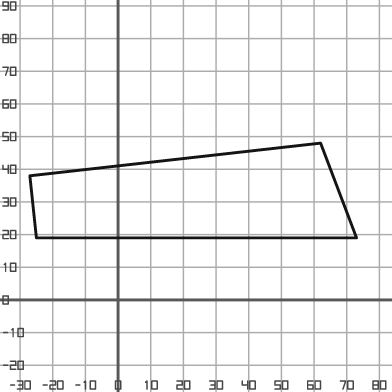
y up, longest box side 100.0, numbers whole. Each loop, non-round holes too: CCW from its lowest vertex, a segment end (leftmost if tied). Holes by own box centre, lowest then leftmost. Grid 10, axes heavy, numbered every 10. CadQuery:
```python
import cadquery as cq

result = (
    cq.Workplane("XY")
    .moveTo(-25.0, 19.0)
    .lineTo(73.0, 19.0)
    .lineTo(62.0, 48.0)
    .lineTo(-27.0, 38.0)
    .close()
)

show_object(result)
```